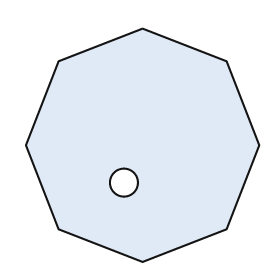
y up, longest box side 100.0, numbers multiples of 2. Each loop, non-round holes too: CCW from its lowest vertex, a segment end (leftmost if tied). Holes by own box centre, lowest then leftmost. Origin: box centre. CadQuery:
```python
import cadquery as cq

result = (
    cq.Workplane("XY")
    .moveTo(0.0, -50.0)
    .lineTo(36.0, -36.0)
    .lineTo(50.0, 0.0)
    .lineTo(36.0, 36.0)
    .lineTo(0.0, 50.0)
    .lineTo(-36.0, 36.0)
    .lineTo(-50.0, 0.0)
    .lineTo(-36.0, -36.0)
    .close()
    .moveTo(-8.0, -16.0)
    .circle(6.0)
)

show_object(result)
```